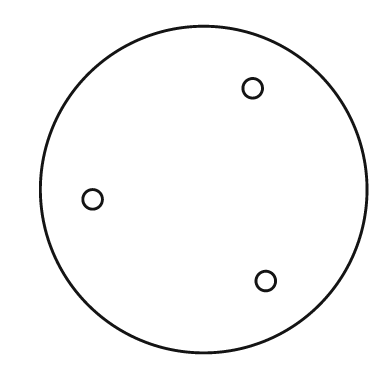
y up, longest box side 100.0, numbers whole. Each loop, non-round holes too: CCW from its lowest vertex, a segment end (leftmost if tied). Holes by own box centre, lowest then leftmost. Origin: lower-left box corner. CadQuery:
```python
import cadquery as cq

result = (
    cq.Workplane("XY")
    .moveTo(50.0, 50.0)
    .circle(50.0)
    .moveTo(69.0, 22.0)
    .circle(3.0)
    .moveTo(16.0, 47.0)
    .circle(3.0)
    .moveTo(65.0, 81.0)
    .circle(3.0)
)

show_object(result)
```